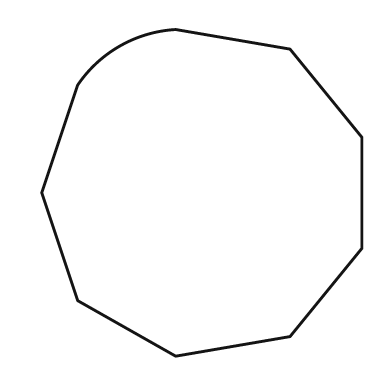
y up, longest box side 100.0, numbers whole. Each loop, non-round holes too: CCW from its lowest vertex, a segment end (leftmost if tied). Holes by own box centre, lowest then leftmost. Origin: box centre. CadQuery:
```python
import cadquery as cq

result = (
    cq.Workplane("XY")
    .moveTo(-8.0, -50.0)
    .lineTo(27.0, -44.0)
    .lineTo(49.0, -17.0)
    .lineTo(49.0, 17.0)
    .lineTo(27.0, 44.0)
    .lineTo(-8.0, 50.0)
    .threePointArc((-25.0, 45.0), (-38.0, 33.0))
    .lineTo(-49.0, 0.0)
    .lineTo(-38.0, -33.0)
    .close()
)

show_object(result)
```